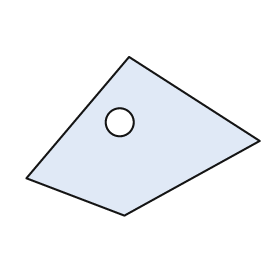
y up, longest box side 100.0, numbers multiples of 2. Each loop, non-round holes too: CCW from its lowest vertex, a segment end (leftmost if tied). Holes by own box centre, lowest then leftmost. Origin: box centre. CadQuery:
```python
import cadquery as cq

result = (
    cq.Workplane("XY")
    .moveTo(-8.0, -34.0)
    .lineTo(50.0, -2.0)
    .lineTo(-6.0, 34.0)
    .lineTo(-50.0, -18.0)
    .close()
    .moveTo(-10.0, 6.0)
    .circle(6.0)
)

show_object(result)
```